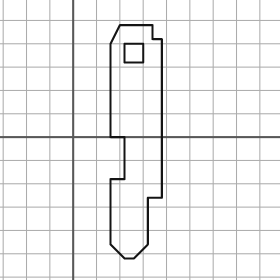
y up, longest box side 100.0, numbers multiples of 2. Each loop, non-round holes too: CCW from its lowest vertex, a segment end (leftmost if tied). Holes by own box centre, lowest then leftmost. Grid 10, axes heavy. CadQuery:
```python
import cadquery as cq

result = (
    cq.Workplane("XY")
    .moveTo(22.0, -52.0)
    .lineTo(26.0, -52.0)
    .lineTo(32.0, -46.0)
    .lineTo(32.0, -26.0)
    .lineTo(38.0, -26.0)
    .lineTo(38.0, 42.0)
    .lineTo(34.0, 42.0)
    .lineTo(34.0, 48.0)
    .lineTo(20.0, 48.0)
    .lineTo(16.0, 40.0)
    .lineTo(16.0, 0.0)
    .lineTo(22.0, 0.0)
    .lineTo(22.0, -18.0)
    .lineTo(16.0, -18.0)
    .lineTo(16.0, -46.0)
    .close()
    .moveTo(22.0, 32.0)
    .lineTo(30.0, 32.0)
    .lineTo(30.0, 40.0)
    .lineTo(22.0, 40.0)
    .close()
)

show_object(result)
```